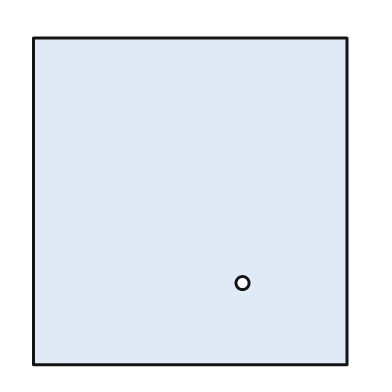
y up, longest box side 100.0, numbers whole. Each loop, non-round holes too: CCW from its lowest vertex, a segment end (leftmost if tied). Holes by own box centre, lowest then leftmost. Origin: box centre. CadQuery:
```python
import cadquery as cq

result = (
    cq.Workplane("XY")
    .moveTo(-48.0, -50.0)
    .lineTo(48.0, -50.0)
    .lineTo(48.0, 50.0)
    .lineTo(-48.0, 50.0)
    .close()
    .moveTo(16.0, -25.0)
    .circle(2.0)
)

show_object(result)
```